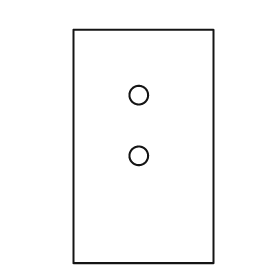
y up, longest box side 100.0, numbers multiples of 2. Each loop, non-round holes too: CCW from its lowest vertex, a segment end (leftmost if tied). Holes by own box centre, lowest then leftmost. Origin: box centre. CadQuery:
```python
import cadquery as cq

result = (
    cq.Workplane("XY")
    .moveTo(-30.0, -50.0)
    .lineTo(30.0, -50.0)
    .lineTo(30.0, 50.0)
    .lineTo(-30.0, 50.0)
    .close()
    .moveTo(-2.0, -4.0)
    .circle(4.0)
    .moveTo(-2.0, 22.0)
    .circle(4.0)
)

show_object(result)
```